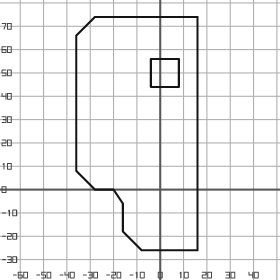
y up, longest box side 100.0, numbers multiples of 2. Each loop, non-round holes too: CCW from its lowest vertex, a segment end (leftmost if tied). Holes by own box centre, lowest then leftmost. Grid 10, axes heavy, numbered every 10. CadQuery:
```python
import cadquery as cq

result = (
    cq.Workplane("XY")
    .moveTo(-8.0, -26.0)
    .lineTo(16.0, -26.0)
    .lineTo(16.0, 74.0)
    .lineTo(-28.0, 74.0)
    .lineTo(-36.0, 66.0)
    .lineTo(-36.0, 8.0)
    .lineTo(-28.0, 0.0)
    .lineTo(-20.0, 0.0)
    .lineTo(-16.0, -6.0)
    .lineTo(-16.0, -18.0)
    .close()
    .moveTo(-4.0, 44.0)
    .lineTo(8.0, 44.0)
    .lineTo(8.0, 56.0)
    .lineTo(-4.0, 56.0)
    .close()
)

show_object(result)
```